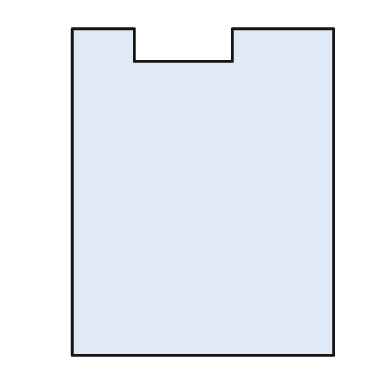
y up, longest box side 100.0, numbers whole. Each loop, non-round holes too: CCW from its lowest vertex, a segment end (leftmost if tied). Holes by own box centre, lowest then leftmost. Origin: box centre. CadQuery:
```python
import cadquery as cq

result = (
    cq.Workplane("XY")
    .moveTo(-40.0, -50.0)
    .lineTo(40.0, -50.0)
    .lineTo(40.0, 50.0)
    .lineTo(9.0, 50.0)
    .lineTo(9.0, 40.0)
    .lineTo(-21.0, 40.0)
    .lineTo(-21.0, 50.0)
    .lineTo(-40.0, 50.0)
    .close()
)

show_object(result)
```